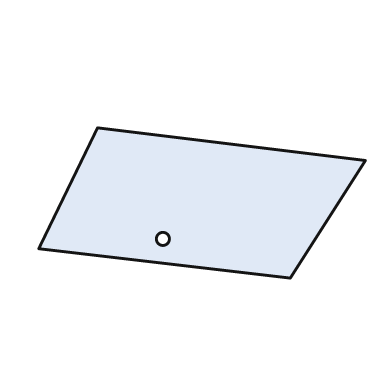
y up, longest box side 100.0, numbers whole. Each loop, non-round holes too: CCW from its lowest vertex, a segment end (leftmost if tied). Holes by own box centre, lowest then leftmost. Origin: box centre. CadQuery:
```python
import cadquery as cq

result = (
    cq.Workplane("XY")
    .moveTo(27.0, -23.0)
    .lineTo(50.0, 13.0)
    .lineTo(-32.0, 23.0)
    .lineTo(-50.0, -14.0)
    .close()
    .moveTo(-12.0, -11.0)
    .circle(2.0)
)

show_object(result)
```